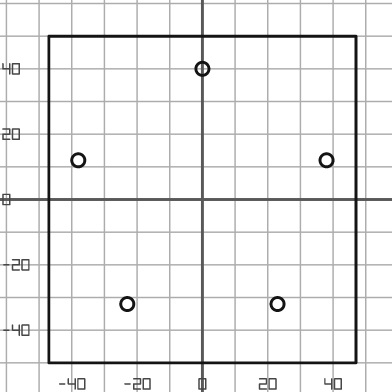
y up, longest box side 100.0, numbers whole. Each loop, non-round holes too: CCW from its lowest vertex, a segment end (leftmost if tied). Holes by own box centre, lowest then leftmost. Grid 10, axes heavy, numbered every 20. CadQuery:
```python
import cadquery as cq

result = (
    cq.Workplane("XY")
    .moveTo(-47.0, -50.0)
    .lineTo(47.0, -50.0)
    .lineTo(47.0, 50.0)
    .lineTo(-47.0, 50.0)
    .close()
    .moveTo(-23.0, -32.0)
    .circle(2.0)
    .moveTo(23.0, -32.0)
    .circle(2.0)
    .moveTo(-38.0, 12.0)
    .circle(2.0)
    .moveTo(38.0, 12.0)
    .circle(2.0)
    .moveTo(0.0, 40.0)
    .circle(2.0)
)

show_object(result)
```